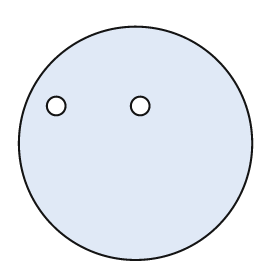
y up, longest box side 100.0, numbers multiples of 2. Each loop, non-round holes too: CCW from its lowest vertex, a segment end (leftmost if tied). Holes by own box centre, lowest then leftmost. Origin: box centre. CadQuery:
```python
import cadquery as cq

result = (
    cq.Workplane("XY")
    .moveTo(0.0, 0.0)
    .circle(50.0)
    .moveTo(-34.0, 16.0)
    .circle(4.0)
    .moveTo(2.0, 16.0)
    .circle(4.0)
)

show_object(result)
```